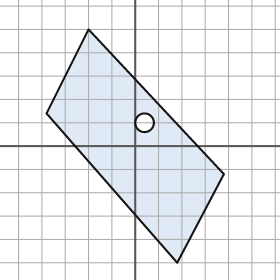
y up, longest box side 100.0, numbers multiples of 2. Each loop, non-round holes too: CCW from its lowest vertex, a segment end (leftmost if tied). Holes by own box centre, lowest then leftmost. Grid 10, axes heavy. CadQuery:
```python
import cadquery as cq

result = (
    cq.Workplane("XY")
    .moveTo(18.0, -50.0)
    .lineTo(38.0, -12.0)
    .lineTo(-20.0, 50.0)
    .lineTo(-38.0, 14.0)
    .close()
    .moveTo(4.0, 10.0)
    .circle(4.0)
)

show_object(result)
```